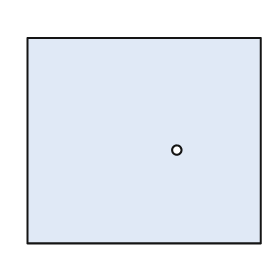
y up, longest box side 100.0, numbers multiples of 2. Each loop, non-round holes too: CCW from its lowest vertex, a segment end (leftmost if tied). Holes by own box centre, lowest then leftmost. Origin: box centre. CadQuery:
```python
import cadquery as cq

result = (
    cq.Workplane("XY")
    .moveTo(-50.0, -44.0)
    .lineTo(50.0, -44.0)
    .lineTo(50.0, 44.0)
    .lineTo(-50.0, 44.0)
    .close()
    .moveTo(14.0, -4.0)
    .circle(2.0)
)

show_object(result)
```